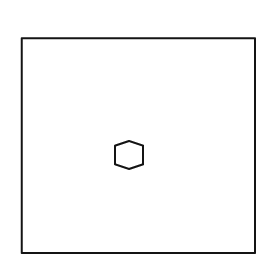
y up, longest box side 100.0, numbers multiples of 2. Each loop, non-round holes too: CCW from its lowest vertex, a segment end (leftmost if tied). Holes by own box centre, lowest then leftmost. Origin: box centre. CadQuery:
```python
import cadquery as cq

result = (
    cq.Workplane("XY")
    .moveTo(-50.0, -46.0)
    .lineTo(50.0, -46.0)
    .lineTo(50.0, 46.0)
    .lineTo(-50.0, 46.0)
    .close()
    .moveTo(-4.0, -10.0)
    .lineTo(2.0, -8.0)
    .lineTo(2.0, 0.0)
    .lineTo(-4.0, 2.0)
    .lineTo(-10.0, 0.0)
    .lineTo(-10.0, -8.0)
    .close()
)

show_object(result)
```